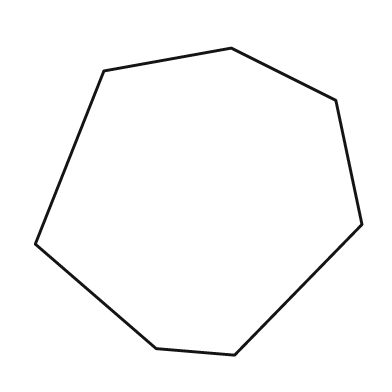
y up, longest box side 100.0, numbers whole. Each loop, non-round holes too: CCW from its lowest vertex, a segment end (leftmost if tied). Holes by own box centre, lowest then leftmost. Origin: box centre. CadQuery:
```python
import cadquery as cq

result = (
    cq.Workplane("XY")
    .moveTo(11.0, -47.0)
    .lineTo(50.0, -7.0)
    .lineTo(42.0, 31.0)
    .lineTo(10.0, 47.0)
    .lineTo(-29.0, 40.0)
    .lineTo(-50.0, -13.0)
    .lineTo(-13.0, -45.0)
    .close()
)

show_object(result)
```